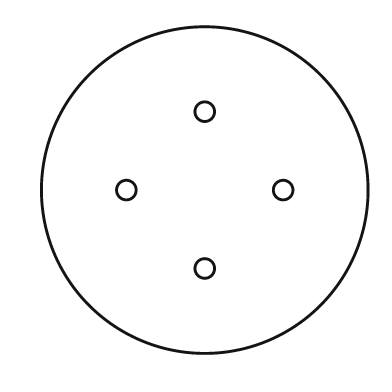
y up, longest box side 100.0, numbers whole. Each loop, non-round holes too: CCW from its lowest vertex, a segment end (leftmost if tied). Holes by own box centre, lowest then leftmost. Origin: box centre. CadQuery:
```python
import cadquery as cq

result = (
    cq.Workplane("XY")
    .moveTo(0.0, 0.0)
    .circle(50.0)
    .moveTo(0.0, -24.0)
    .circle(3.0)
    .moveTo(-24.0, 0.0)
    .circle(3.0)
    .moveTo(24.0, 0.0)
    .circle(3.0)
    .moveTo(0.0, 24.0)
    .circle(3.0)
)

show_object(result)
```